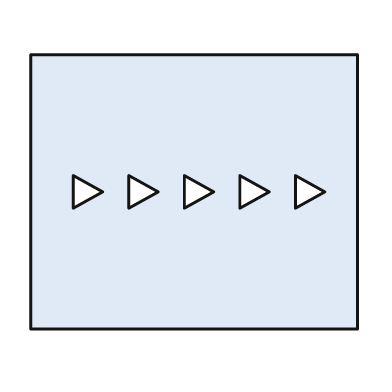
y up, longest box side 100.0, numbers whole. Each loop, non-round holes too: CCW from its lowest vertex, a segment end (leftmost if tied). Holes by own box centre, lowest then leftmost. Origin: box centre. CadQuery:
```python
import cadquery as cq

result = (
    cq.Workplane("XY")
    .moveTo(-50.0, -42.0)
    .lineTo(50.0, -42.0)
    .lineTo(50.0, 42.0)
    .lineTo(-50.0, 42.0)
    .close()
    .moveTo(-37.0, -5.0)
    .lineTo(-28.0, 0.0)
    .lineTo(-37.0, 5.0)
    .close()
    .moveTo(-20.0, -5.0)
    .lineTo(-11.0, 0.0)
    .lineTo(-20.0, 5.0)
    .close()
    .moveTo(-3.0, -5.0)
    .lineTo(6.0, 0.0)
    .lineTo(-3.0, 5.0)
    .close()
    .moveTo(14.0, -5.0)
    .lineTo(23.0, 0.0)
    .lineTo(14.0, 5.0)
    .close()
    .moveTo(31.0, -5.0)
    .lineTo(40.0, 0.0)
    .lineTo(31.0, 5.0)
    .close()
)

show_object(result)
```